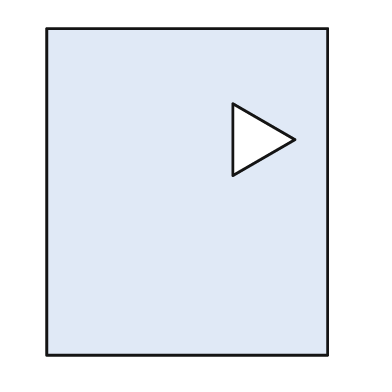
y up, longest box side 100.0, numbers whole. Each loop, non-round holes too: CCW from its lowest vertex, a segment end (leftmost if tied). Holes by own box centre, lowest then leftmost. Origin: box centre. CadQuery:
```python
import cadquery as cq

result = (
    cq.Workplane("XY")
    .moveTo(-43.0, -50.0)
    .lineTo(43.0, -50.0)
    .lineTo(43.0, 50.0)
    .lineTo(-43.0, 50.0)
    .close()
    .moveTo(14.0, 5.0)
    .lineTo(33.0, 16.0)
    .lineTo(14.0, 27.0)
    .close()
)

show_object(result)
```